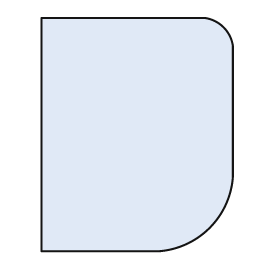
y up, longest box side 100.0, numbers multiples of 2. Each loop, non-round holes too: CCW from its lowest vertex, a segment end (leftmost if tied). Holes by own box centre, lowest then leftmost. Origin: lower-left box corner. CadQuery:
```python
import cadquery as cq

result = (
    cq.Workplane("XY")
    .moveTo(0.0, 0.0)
    .lineTo(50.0, 0.0)
    .threePointArc((72.0, 10.0), (82.0, 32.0))
    .lineTo(82.0, 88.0)
    .threePointArc((78.0, 96.0), (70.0, 100.0))
    .lineTo(0.0, 100.0)
    .close()
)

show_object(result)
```